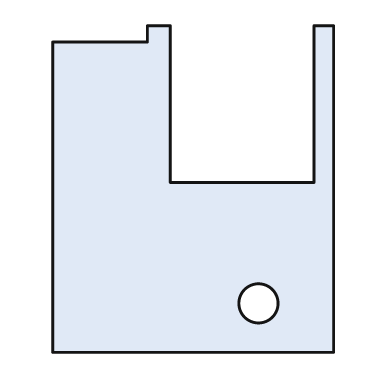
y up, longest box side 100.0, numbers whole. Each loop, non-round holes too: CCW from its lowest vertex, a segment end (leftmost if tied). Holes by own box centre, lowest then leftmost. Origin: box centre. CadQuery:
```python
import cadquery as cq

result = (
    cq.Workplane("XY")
    .moveTo(-43.0, -50.0)
    .lineTo(43.0, -50.0)
    .lineTo(43.0, 50.0)
    .lineTo(37.0, 50.0)
    .lineTo(37.0, 2.0)
    .lineTo(-7.0, 2.0)
    .lineTo(-7.0, 50.0)
    .lineTo(-14.0, 50.0)
    .lineTo(-14.0, 45.0)
    .lineTo(-43.0, 45.0)
    .close()
    .moveTo(20.0, -35.0)
    .circle(6.0)
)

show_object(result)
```